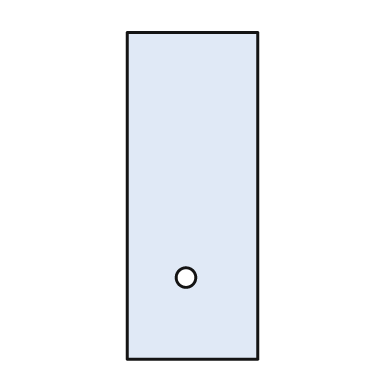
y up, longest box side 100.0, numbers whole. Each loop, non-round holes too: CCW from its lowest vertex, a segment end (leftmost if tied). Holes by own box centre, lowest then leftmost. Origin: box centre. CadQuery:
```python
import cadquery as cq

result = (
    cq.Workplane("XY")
    .moveTo(-20.0, -50.0)
    .lineTo(20.0, -50.0)
    .lineTo(20.0, 50.0)
    .lineTo(-20.0, 50.0)
    .close()
    .moveTo(-2.0, -25.0)
    .circle(3.0)
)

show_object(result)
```